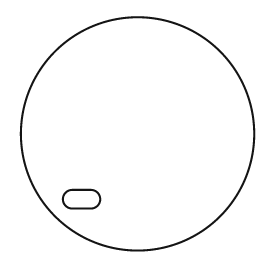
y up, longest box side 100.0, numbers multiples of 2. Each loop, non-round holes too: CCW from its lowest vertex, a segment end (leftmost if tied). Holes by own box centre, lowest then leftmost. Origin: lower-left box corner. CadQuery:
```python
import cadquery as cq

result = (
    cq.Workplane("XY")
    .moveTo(50.0, 50.0)
    .circle(50.0)
    .moveTo(22.0, 18.0)
    .lineTo(30.0, 18.0)
    .threePointArc((34.0, 22.0), (30.0, 26.0))
    .lineTo(22.0, 26.0)
    .threePointArc((18.0, 22.0), (22.0, 18.0))
    .close()
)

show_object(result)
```